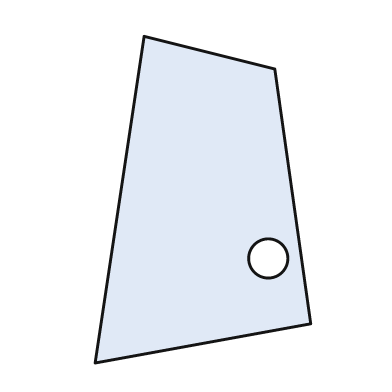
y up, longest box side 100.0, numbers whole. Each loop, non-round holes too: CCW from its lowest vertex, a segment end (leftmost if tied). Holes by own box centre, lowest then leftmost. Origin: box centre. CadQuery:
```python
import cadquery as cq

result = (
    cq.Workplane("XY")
    .moveTo(-33.0, -50.0)
    .lineTo(33.0, -38.0)
    .lineTo(22.0, 40.0)
    .lineTo(-18.0, 50.0)
    .close()
    .moveTo(20.0, -18.0)
    .circle(6.0)
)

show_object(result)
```